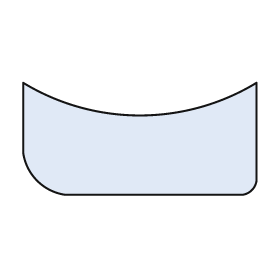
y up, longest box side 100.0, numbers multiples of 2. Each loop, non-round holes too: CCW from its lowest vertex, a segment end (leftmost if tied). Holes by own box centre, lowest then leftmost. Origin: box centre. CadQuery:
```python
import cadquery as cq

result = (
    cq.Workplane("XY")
    .moveTo(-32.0, -24.0)
    .lineTo(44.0, -24.0)
    .threePointArc((48.0, -22.0), (50.0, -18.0))
    .lineTo(50.0, 24.0)
    .threePointArc((0.0, 10.0), (-50.0, 24.0))
    .lineTo(-50.0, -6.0)
    .threePointArc((-44.0, -18.0), (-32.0, -24.0))
    .close()
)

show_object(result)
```